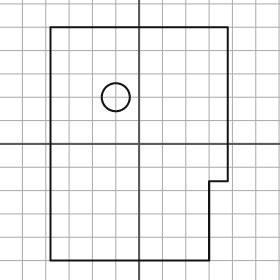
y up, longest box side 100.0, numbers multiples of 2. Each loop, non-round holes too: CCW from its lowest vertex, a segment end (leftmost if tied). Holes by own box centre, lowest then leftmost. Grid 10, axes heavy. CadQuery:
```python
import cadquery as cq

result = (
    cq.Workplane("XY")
    .moveTo(-38.0, -50.0)
    .lineTo(30.0, -50.0)
    .lineTo(30.0, -16.0)
    .lineTo(38.0, -16.0)
    .lineTo(38.0, 50.0)
    .lineTo(-38.0, 50.0)
    .close()
    .moveTo(-10.0, 20.0)
    .circle(6.0)
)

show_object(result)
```